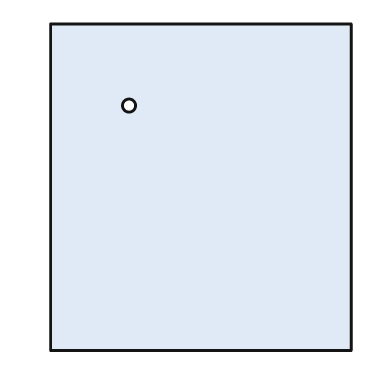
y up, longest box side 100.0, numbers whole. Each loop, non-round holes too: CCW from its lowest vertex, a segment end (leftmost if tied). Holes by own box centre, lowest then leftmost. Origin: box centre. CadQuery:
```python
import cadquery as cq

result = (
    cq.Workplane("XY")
    .moveTo(-46.0, -50.0)
    .lineTo(46.0, -50.0)
    .lineTo(46.0, 50.0)
    .lineTo(-46.0, 50.0)
    .close()
    .moveTo(-22.0, 25.0)
    .circle(2.0)
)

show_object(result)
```